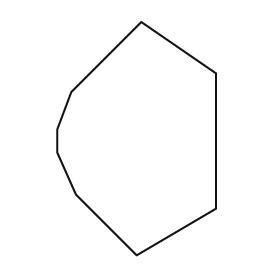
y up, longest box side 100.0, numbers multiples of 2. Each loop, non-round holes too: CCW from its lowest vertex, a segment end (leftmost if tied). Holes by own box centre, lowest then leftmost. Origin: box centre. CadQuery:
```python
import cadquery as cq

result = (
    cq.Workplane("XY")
    .moveTo(0.0, -50.0)
    .lineTo(34.0, -30.0)
    .lineTo(34.0, 28.0)
    .lineTo(2.0, 50.0)
    .lineTo(-28.0, 20.0)
    .lineTo(-34.0, 4.0)
    .lineTo(-34.0, -6.0)
    .lineTo(-26.0, -24.0)
    .close()
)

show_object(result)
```